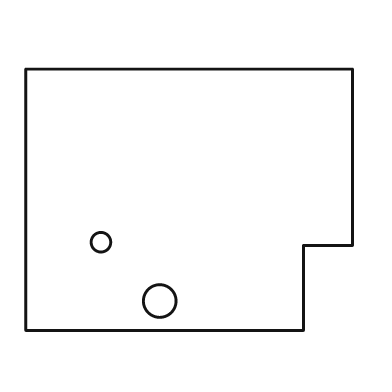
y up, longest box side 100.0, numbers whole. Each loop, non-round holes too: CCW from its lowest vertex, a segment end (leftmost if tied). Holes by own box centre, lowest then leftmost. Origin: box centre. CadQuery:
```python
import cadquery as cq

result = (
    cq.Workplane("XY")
    .moveTo(-50.0, -40.0)
    .lineTo(35.0, -40.0)
    .lineTo(35.0, -14.0)
    .lineTo(50.0, -14.0)
    .lineTo(50.0, 40.0)
    .lineTo(-50.0, 40.0)
    .close()
    .moveTo(-9.0, -31.0)
    .circle(5.0)
    .moveTo(-27.0, -13.0)
    .circle(3.0)
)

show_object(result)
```